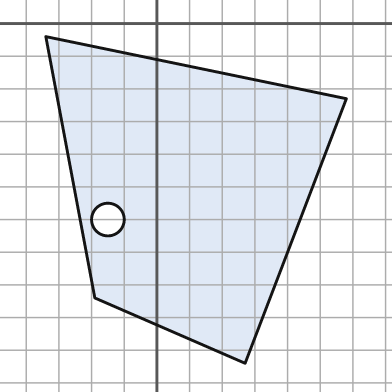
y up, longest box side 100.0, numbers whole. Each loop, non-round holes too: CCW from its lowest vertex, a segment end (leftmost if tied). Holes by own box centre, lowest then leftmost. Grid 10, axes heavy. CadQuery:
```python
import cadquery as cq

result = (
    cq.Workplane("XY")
    .moveTo(27.0, -104.0)
    .lineTo(58.0, -23.0)
    .lineTo(-34.0, -4.0)
    .lineTo(-19.0, -84.0)
    .close()
    .moveTo(-15.0, -60.0)
    .circle(5.0)
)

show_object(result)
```